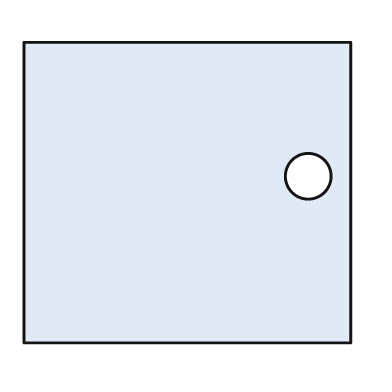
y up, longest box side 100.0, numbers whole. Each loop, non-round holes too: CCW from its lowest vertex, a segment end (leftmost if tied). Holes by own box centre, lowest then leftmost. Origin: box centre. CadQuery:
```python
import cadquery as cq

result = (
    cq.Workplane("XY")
    .moveTo(-50.0, -46.0)
    .lineTo(50.0, -46.0)
    .lineTo(50.0, 46.0)
    .lineTo(-50.0, 46.0)
    .close()
    .moveTo(37.0, 5.0)
    .circle(7.0)
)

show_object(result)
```